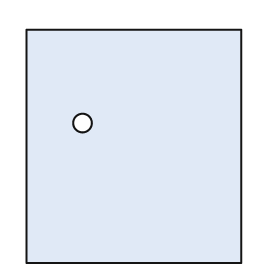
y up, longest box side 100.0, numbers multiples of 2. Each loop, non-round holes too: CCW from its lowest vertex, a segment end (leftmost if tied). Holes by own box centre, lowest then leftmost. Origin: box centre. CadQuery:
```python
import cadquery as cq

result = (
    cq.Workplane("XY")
    .moveTo(-46.0, -50.0)
    .lineTo(46.0, -50.0)
    .lineTo(46.0, 50.0)
    .lineTo(-46.0, 50.0)
    .close()
    .moveTo(-22.0, 10.0)
    .circle(4.0)
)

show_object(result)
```